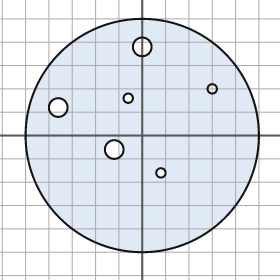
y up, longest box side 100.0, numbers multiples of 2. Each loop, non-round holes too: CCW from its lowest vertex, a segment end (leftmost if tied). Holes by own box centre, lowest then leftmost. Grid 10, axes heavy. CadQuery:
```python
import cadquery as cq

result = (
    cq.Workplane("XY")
    .moveTo(0.0, 0.0)
    .circle(50.0)
    .moveTo(8.0, -16.0)
    .circle(2.0)
    .moveTo(-12.0, -6.0)
    .circle(4.0)
    .moveTo(-36.0, 12.0)
    .circle(4.0)
    .moveTo(-6.0, 16.0)
    .circle(2.0)
    .moveTo(30.0, 20.0)
    .circle(2.0)
    .moveTo(0.0, 38.0)
    .circle(4.0)
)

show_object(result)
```